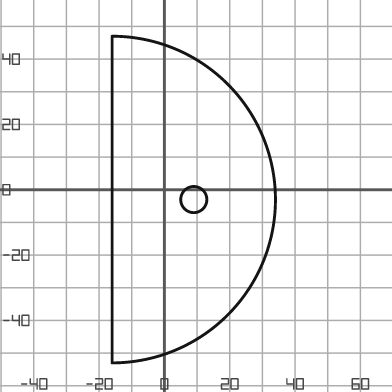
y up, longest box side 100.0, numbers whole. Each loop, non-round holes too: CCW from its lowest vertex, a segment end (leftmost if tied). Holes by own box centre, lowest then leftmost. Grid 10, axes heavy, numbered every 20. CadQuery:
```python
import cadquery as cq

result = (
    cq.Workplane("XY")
    .moveTo(-16.0, -53.0)
    .threePointArc((34.0, -3.0), (-16.0, 47.0))
    .close()
    .moveTo(9.0, -3.0)
    .circle(4.0)
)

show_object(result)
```